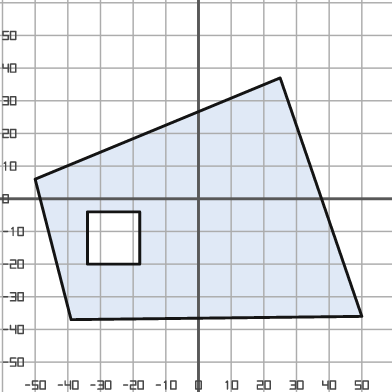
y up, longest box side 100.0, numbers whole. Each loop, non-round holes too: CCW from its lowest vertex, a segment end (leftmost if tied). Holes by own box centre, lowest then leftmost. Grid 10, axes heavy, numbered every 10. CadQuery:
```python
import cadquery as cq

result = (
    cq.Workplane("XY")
    .moveTo(-39.0, -37.0)
    .lineTo(50.0, -36.0)
    .lineTo(25.0, 37.0)
    .lineTo(-50.0, 6.0)
    .close()
    .moveTo(-34.0, -20.0)
    .lineTo(-18.0, -20.0)
    .lineTo(-18.0, -4.0)
    .lineTo(-34.0, -4.0)
    .close()
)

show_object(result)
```